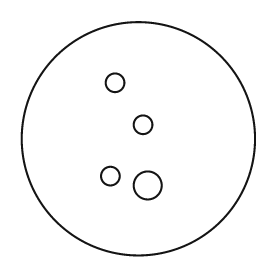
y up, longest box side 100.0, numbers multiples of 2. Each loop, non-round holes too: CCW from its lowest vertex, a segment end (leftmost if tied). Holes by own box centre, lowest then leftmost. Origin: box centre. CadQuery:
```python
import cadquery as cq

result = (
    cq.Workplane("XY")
    .moveTo(0.0, 0.0)
    .circle(50.0)
    .moveTo(4.0, -20.0)
    .circle(6.0)
    .moveTo(-12.0, -16.0)
    .circle(4.0)
    .moveTo(2.0, 6.0)
    .circle(4.0)
    .moveTo(-10.0, 24.0)
    .circle(4.0)
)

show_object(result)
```